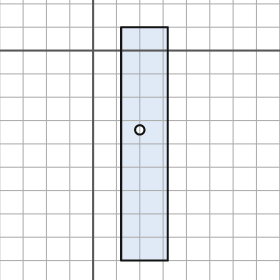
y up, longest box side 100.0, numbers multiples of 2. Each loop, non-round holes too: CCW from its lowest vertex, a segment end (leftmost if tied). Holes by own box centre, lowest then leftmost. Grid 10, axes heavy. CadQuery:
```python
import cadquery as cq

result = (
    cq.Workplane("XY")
    .moveTo(12.0, -90.0)
    .lineTo(32.0, -90.0)
    .lineTo(32.0, 10.0)
    .lineTo(12.0, 10.0)
    .close()
    .moveTo(20.0, -34.0)
    .circle(2.0)
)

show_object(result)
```